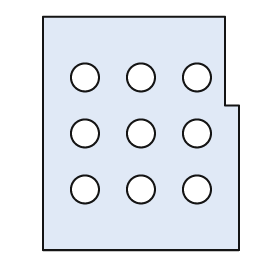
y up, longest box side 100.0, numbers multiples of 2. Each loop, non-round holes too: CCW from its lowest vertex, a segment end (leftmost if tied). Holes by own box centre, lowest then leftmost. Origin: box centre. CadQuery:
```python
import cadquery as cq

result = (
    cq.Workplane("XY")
    .moveTo(-42.0, -50.0)
    .lineTo(42.0, -50.0)
    .lineTo(42.0, 12.0)
    .lineTo(36.0, 12.0)
    .lineTo(36.0, 50.0)
    .lineTo(-42.0, 50.0)
    .close()
    .moveTo(-24.0, -24.0)
    .circle(6.0)
    .moveTo(0.0, -24.0)
    .circle(6.0)
    .moveTo(24.0, -24.0)
    .circle(6.0)
    .moveTo(-24.0, 0.0)
    .circle(6.0)
    .moveTo(0.0, 0.0)
    .circle(6.0)
    .moveTo(24.0, 0.0)
    .circle(6.0)
    .moveTo(-24.0, 24.0)
    .circle(6.0)
    .moveTo(0.0, 24.0)
    .circle(6.0)
    .moveTo(24.0, 24.0)
    .circle(6.0)
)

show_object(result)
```